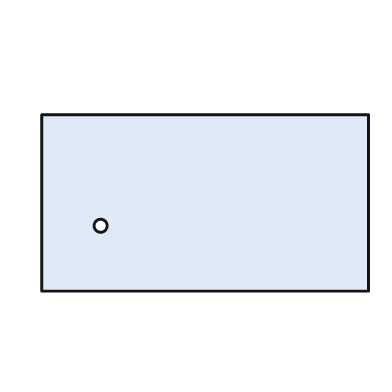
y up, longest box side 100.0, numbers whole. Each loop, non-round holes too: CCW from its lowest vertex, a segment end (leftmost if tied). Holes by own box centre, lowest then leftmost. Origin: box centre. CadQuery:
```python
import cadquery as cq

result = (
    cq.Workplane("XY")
    .moveTo(-50.0, -27.0)
    .lineTo(50.0, -27.0)
    .lineTo(50.0, 27.0)
    .lineTo(-50.0, 27.0)
    .close()
    .moveTo(-32.0, -7.0)
    .circle(2.0)
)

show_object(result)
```